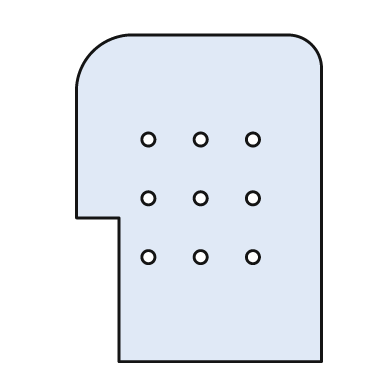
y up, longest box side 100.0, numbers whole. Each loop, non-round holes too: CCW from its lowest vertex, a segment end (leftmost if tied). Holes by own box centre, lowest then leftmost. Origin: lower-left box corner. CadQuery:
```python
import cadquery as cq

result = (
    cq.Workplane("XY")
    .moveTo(13.0, 0.0)
    .lineTo(75.0, 0.0)
    .lineTo(75.0, 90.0)
    .threePointArc((72.0, 97.0), (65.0, 100.0))
    .lineTo(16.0, 100.0)
    .threePointArc((5.0, 95.0), (0.0, 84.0))
    .lineTo(0.0, 44.0)
    .lineTo(13.0, 44.0)
    .close()
    .moveTo(22.0, 32.0)
    .circle(2.0)
    .moveTo(38.0, 32.0)
    .circle(2.0)
    .moveTo(54.0, 32.0)
    .circle(2.0)
    .moveTo(22.0, 50.0)
    .circle(2.0)
    .moveTo(38.0, 50.0)
    .circle(2.0)
    .moveTo(54.0, 50.0)
    .circle(2.0)
    .moveTo(22.0, 68.0)
    .circle(2.0)
    .moveTo(38.0, 68.0)
    .circle(2.0)
    .moveTo(54.0, 68.0)
    .circle(2.0)
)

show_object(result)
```